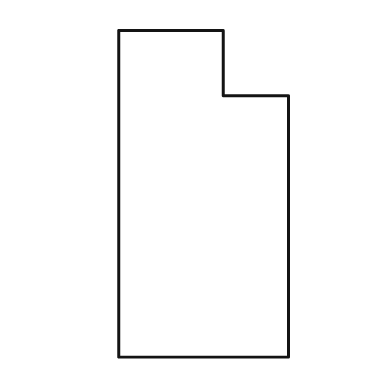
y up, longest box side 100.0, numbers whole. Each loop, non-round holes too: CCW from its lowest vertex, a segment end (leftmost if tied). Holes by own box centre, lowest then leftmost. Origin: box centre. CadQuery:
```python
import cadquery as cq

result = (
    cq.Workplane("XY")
    .moveTo(-26.0, -50.0)
    .lineTo(26.0, -50.0)
    .lineTo(26.0, 30.0)
    .lineTo(6.0, 30.0)
    .lineTo(6.0, 50.0)
    .lineTo(-26.0, 50.0)
    .close()
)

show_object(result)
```